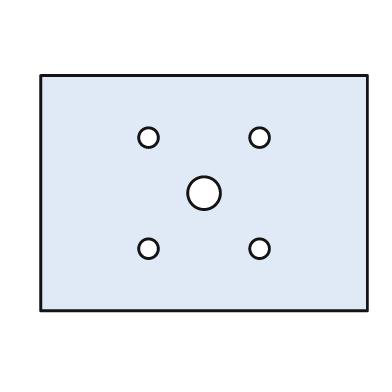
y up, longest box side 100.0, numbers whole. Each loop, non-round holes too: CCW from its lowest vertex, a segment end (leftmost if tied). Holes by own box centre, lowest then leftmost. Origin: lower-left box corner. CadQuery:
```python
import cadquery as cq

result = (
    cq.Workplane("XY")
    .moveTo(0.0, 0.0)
    .lineTo(100.0, 0.0)
    .lineTo(100.0, 72.0)
    .lineTo(0.0, 72.0)
    .close()
    .moveTo(33.0, 19.0)
    .circle(3.0)
    .moveTo(67.0, 19.0)
    .circle(3.0)
    .moveTo(50.0, 36.0)
    .circle(5.0)
    .moveTo(33.0, 53.0)
    .circle(3.0)
    .moveTo(67.0, 53.0)
    .circle(3.0)
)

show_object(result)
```